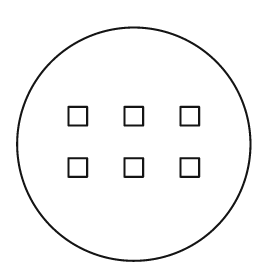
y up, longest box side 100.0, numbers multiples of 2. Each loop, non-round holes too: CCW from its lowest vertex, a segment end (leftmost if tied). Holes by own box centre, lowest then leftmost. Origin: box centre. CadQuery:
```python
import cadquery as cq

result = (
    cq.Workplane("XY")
    .moveTo(0.0, 0.0)
    .circle(50.0)
    .moveTo(-28.0, -14.0)
    .lineTo(-20.0, -14.0)
    .lineTo(-20.0, -6.0)
    .lineTo(-28.0, -6.0)
    .close()
    .moveTo(-4.0, -14.0)
    .lineTo(4.0, -14.0)
    .lineTo(4.0, -6.0)
    .lineTo(-4.0, -6.0)
    .close()
    .moveTo(20.0, -14.0)
    .lineTo(28.0, -14.0)
    .lineTo(28.0, -6.0)
    .lineTo(20.0, -6.0)
    .close()
    .moveTo(-28.0, 8.0)
    .lineTo(-20.0, 8.0)
    .lineTo(-20.0, 16.0)
    .lineTo(-28.0, 16.0)
    .close()
    .moveTo(-4.0, 8.0)
    .lineTo(4.0, 8.0)
    .lineTo(4.0, 16.0)
    .lineTo(-4.0, 16.0)
    .close()
    .moveTo(20.0, 8.0)
    .lineTo(28.0, 8.0)
    .lineTo(28.0, 16.0)
    .lineTo(20.0, 16.0)
    .close()
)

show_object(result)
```